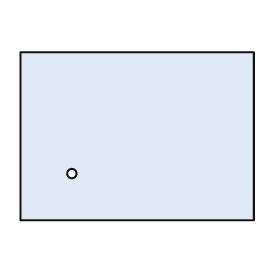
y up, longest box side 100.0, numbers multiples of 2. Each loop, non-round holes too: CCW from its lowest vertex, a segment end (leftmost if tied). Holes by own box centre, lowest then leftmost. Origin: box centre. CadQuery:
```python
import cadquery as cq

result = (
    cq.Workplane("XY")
    .moveTo(-50.0, -36.0)
    .lineTo(50.0, -36.0)
    .lineTo(50.0, 36.0)
    .lineTo(-50.0, 36.0)
    .close()
    .moveTo(-28.0, -16.0)
    .circle(2.0)
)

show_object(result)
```